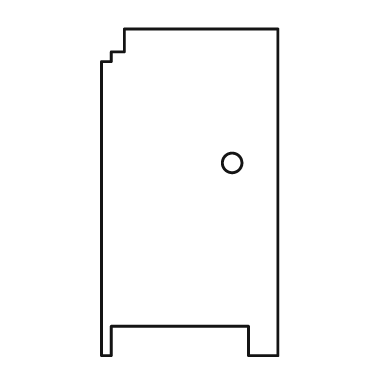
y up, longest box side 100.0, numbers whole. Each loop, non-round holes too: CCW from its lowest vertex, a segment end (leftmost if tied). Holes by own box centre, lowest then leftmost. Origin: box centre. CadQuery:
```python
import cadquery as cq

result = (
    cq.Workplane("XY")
    .moveTo(-27.0, -50.0)
    .lineTo(-24.0, -50.0)
    .lineTo(-24.0, -41.0)
    .lineTo(18.0, -41.0)
    .lineTo(18.0, -50.0)
    .lineTo(27.0, -50.0)
    .lineTo(27.0, 50.0)
    .lineTo(-20.0, 50.0)
    .lineTo(-20.0, 43.0)
    .lineTo(-24.0, 43.0)
    .lineTo(-24.0, 40.0)
    .lineTo(-27.0, 40.0)
    .close()
    .moveTo(13.0, 9.0)
    .circle(3.0)
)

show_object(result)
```